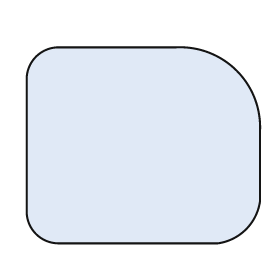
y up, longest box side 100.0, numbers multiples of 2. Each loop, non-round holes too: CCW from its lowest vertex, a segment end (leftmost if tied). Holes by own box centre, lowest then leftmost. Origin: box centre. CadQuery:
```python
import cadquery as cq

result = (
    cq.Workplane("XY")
    .moveTo(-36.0, -42.0)
    .lineTo(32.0, -42.0)
    .threePointArc((44.0, -36.0), (50.0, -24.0))
    .lineTo(50.0, 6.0)
    .threePointArc((40.0, 32.0), (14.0, 42.0))
    .lineTo(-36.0, 42.0)
    .threePointArc((-46.0, 38.0), (-50.0, 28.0))
    .lineTo(-50.0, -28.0)
    .threePointArc((-46.0, -38.0), (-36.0, -42.0))
    .close()
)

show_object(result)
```